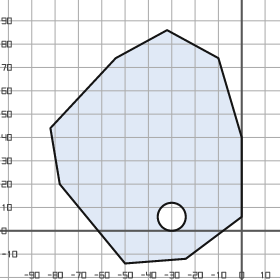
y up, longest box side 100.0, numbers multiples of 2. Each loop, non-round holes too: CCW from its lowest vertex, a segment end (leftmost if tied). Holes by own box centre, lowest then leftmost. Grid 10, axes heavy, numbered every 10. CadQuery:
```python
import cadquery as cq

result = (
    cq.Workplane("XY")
    .moveTo(-50.0, -14.0)
    .lineTo(-24.0, -12.0)
    .lineTo(0.0, 6.0)
    .lineTo(0.0, 40.0)
    .lineTo(-10.0, 74.0)
    .lineTo(-32.0, 86.0)
    .lineTo(-54.0, 74.0)
    .lineTo(-82.0, 44.0)
    .lineTo(-78.0, 20.0)
    .close()
    .moveTo(-30.0, 6.0)
    .circle(6.0)
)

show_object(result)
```